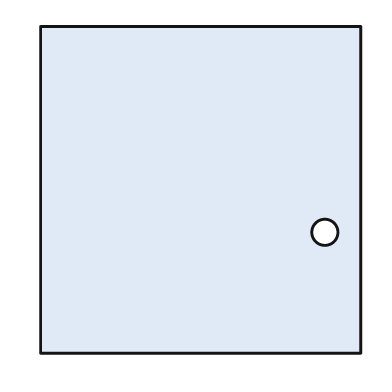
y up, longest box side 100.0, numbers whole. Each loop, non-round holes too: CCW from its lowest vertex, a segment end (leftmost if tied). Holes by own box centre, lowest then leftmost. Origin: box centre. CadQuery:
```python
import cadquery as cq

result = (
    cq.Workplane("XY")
    .moveTo(-49.0, -50.0)
    .lineTo(49.0, -50.0)
    .lineTo(49.0, 50.0)
    .lineTo(-49.0, 50.0)
    .close()
    .moveTo(38.0, -13.0)
    .circle(4.0)
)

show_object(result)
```